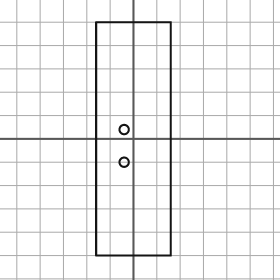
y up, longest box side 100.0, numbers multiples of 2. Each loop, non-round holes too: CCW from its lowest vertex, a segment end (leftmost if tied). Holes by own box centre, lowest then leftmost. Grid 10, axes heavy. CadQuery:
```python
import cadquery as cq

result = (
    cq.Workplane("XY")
    .moveTo(-16.0, -50.0)
    .lineTo(16.0, -50.0)
    .lineTo(16.0, 50.0)
    .lineTo(-16.0, 50.0)
    .close()
    .moveTo(-4.0, -10.0)
    .circle(2.0)
    .moveTo(-4.0, 4.0)
    .circle(2.0)
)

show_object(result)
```